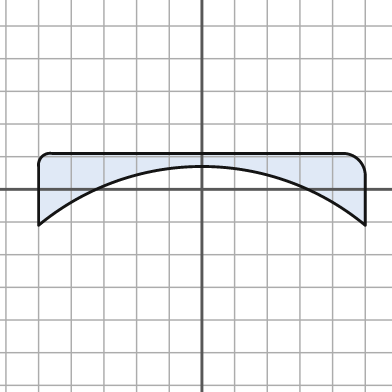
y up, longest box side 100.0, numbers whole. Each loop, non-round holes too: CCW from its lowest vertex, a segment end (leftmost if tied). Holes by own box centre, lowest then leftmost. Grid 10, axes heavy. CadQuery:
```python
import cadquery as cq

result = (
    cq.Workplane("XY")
    .moveTo(-50.0, -11.0)
    .threePointArc((0.0, 7.0), (50.0, -11.0))
    .lineTo(50.0, 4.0)
    .threePointArc((48.0, 9.0), (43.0, 11.0))
    .lineTo(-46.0, 11.0)
    .threePointArc((-49.0, 10.0), (-50.0, 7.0))
    .close()
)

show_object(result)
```